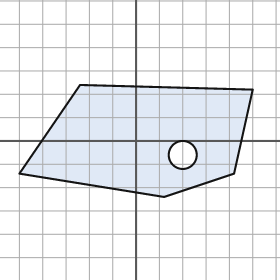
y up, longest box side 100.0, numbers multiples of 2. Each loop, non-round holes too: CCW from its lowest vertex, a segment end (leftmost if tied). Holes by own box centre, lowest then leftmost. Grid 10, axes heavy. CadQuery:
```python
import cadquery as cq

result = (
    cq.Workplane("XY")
    .moveTo(12.0, -24.0)
    .lineTo(42.0, -14.0)
    .lineTo(50.0, 22.0)
    .lineTo(-24.0, 24.0)
    .lineTo(-50.0, -14.0)
    .close()
    .moveTo(20.0, -6.0)
    .circle(6.0)
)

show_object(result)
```